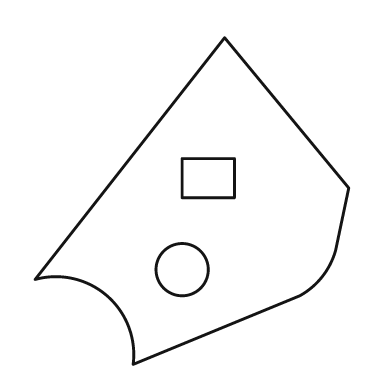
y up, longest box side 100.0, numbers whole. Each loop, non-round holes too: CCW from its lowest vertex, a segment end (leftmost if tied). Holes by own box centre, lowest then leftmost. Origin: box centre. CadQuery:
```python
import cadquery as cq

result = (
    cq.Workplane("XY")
    .moveTo(-18.0, -50.0)
    .lineTo(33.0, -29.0)
    .threePointArc((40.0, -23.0), (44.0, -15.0))
    .lineTo(48.0, 4.0)
    .lineTo(10.0, 50.0)
    .lineTo(-48.0, -24.0)
    .threePointArc((-26.0, -29.0), (-18.0, -50.0))
    .close()
    .moveTo(-3.0, -21.0)
    .circle(8.0)
    .moveTo(-3.0, 1.0)
    .lineTo(13.0, 1.0)
    .lineTo(13.0, 13.0)
    .lineTo(-3.0, 13.0)
    .close()
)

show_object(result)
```